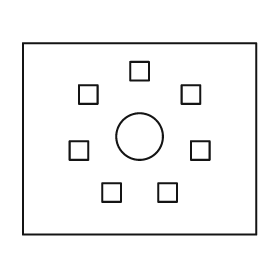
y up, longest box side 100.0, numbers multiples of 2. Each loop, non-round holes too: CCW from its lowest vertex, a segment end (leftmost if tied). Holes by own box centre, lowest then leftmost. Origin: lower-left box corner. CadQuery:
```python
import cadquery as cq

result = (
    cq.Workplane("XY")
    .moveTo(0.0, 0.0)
    .lineTo(100.0, 0.0)
    .lineTo(100.0, 82.0)
    .lineTo(0.0, 82.0)
    .close()
    .moveTo(34.0, 14.0)
    .lineTo(42.0, 14.0)
    .lineTo(42.0, 22.0)
    .lineTo(34.0, 22.0)
    .close()
    .moveTo(58.0, 14.0)
    .lineTo(66.0, 14.0)
    .lineTo(66.0, 22.0)
    .lineTo(58.0, 22.0)
    .close()
    .moveTo(20.0, 32.0)
    .lineTo(28.0, 32.0)
    .lineTo(28.0, 40.0)
    .lineTo(20.0, 40.0)
    .close()
    .moveTo(72.0, 32.0)
    .lineTo(80.0, 32.0)
    .lineTo(80.0, 40.0)
    .lineTo(72.0, 40.0)
    .close()
    .moveTo(50.0, 42.0)
    .circle(10.0)
    .moveTo(24.0, 56.0)
    .lineTo(32.0, 56.0)
    .lineTo(32.0, 64.0)
    .lineTo(24.0, 64.0)
    .close()
    .moveTo(68.0, 56.0)
    .lineTo(76.0, 56.0)
    .lineTo(76.0, 64.0)
    .lineTo(68.0, 64.0)
    .close()
    .moveTo(46.0, 66.0)
    .lineTo(54.0, 66.0)
    .lineTo(54.0, 74.0)
    .lineTo(46.0, 74.0)
    .close()
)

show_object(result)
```